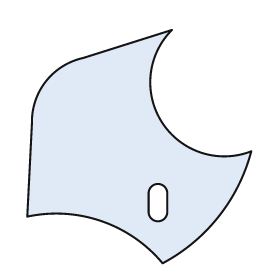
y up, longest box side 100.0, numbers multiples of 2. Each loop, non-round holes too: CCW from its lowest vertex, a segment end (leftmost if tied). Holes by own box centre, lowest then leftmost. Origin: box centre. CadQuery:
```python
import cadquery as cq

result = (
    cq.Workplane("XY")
    .moveTo(10.0, -50.0)
    .threePointArc((34.0, -30.0), (48.0, -2.0))
    .threePointArc((10.0, 10.0), (14.0, 50.0))
    .lineTo(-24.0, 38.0)
    .threePointArc((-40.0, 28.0), (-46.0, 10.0))
    .lineTo(-48.0, -30.0)
    .threePointArc((-16.0, -32.0), (10.0, -50.0))
    .close()
    .moveTo(4.0, -28.0)
    .threePointArc((8.0, -32.0), (12.0, -28.0))
    .lineTo(12.0, -20.0)
    .threePointArc((8.0, -16.0), (4.0, -20.0))
    .close()
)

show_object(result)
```